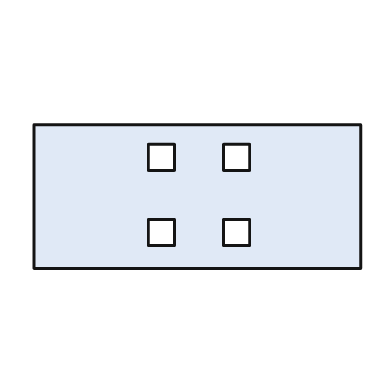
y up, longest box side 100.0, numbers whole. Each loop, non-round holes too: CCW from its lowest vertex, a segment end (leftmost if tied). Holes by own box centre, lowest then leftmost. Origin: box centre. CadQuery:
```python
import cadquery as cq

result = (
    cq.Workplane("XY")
    .moveTo(-50.0, -22.0)
    .lineTo(50.0, -22.0)
    .lineTo(50.0, 22.0)
    .lineTo(-50.0, 22.0)
    .close()
    .moveTo(-15.0, -15.0)
    .lineTo(-7.0, -15.0)
    .lineTo(-7.0, -7.0)
    .lineTo(-15.0, -7.0)
    .close()
    .moveTo(8.0, -15.0)
    .lineTo(16.0, -15.0)
    .lineTo(16.0, -7.0)
    .lineTo(8.0, -7.0)
    .close()
    .moveTo(-15.0, 8.0)
    .lineTo(-7.0, 8.0)
    .lineTo(-7.0, 16.0)
    .lineTo(-15.0, 16.0)
    .close()
    .moveTo(8.0, 8.0)
    .lineTo(16.0, 8.0)
    .lineTo(16.0, 16.0)
    .lineTo(8.0, 16.0)
    .close()
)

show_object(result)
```